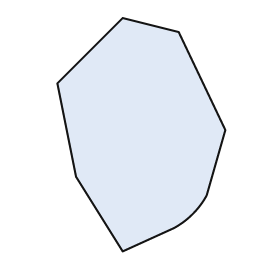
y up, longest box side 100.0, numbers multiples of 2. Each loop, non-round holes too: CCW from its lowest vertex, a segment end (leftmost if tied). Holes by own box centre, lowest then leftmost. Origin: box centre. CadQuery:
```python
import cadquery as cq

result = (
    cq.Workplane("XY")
    .moveTo(-8.0, -50.0)
    .lineTo(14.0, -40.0)
    .threePointArc((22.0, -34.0), (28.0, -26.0))
    .lineTo(36.0, 2.0)
    .lineTo(16.0, 44.0)
    .lineTo(-8.0, 50.0)
    .lineTo(-36.0, 22.0)
    .lineTo(-28.0, -18.0)
    .close()
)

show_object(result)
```